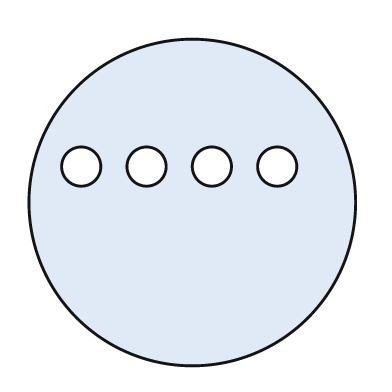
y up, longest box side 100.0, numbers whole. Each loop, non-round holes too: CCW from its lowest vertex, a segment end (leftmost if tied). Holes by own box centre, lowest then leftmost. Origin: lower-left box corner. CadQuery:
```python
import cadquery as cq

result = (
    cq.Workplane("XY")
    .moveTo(50.0, 50.0)
    .circle(50.0)
    .moveTo(16.0, 61.0)
    .circle(6.0)
    .moveTo(36.0, 61.0)
    .circle(6.0)
    .moveTo(56.0, 61.0)
    .circle(6.0)
    .moveTo(76.0, 61.0)
    .circle(6.0)
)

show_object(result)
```